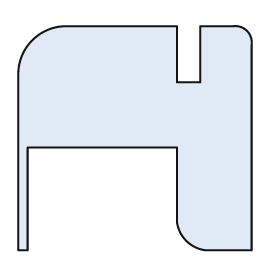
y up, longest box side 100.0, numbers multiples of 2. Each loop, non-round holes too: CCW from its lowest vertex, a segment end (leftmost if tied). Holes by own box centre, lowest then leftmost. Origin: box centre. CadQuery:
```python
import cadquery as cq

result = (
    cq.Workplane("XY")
    .moveTo(-50.0, -48.0)
    .lineTo(-46.0, -48.0)
    .lineTo(-46.0, -4.0)
    .lineTo(18.0, -4.0)
    .lineTo(18.0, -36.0)
    .threePointArc((22.0, -44.0), (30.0, -48.0))
    .lineTo(50.0, -48.0)
    .lineTo(50.0, 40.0)
    .threePointArc((48.0, 46.0), (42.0, 48.0))
    .lineTo(28.0, 48.0)
    .lineTo(28.0, 24.0)
    .lineTo(18.0, 24.0)
    .lineTo(18.0, 48.0)
    .lineTo(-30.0, 48.0)
    .threePointArc((-44.0, 42.0), (-50.0, 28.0))
    .close()
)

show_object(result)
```